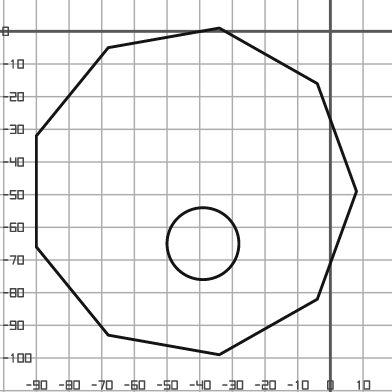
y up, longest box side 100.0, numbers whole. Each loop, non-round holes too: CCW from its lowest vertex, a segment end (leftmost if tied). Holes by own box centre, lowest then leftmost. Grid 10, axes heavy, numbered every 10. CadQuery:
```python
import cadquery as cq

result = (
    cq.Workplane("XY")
    .moveTo(-34.0, -99.0)
    .lineTo(-4.0, -82.0)
    .lineTo(8.0, -49.0)
    .lineTo(-4.0, -16.0)
    .lineTo(-34.0, 1.0)
    .lineTo(-68.0, -5.0)
    .lineTo(-90.0, -32.0)
    .lineTo(-90.0, -66.0)
    .lineTo(-68.0, -93.0)
    .close()
    .moveTo(-39.0, -65.0)
    .circle(11.0)
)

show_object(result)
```